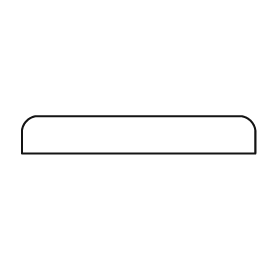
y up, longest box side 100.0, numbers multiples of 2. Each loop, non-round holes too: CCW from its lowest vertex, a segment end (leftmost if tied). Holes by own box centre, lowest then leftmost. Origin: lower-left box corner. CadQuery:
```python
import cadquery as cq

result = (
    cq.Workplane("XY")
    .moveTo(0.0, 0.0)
    .lineTo(100.0, 0.0)
    .lineTo(100.0, 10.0)
    .threePointArc((98.0, 14.0), (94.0, 16.0))
    .lineTo(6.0, 16.0)
    .threePointArc((2.0, 14.0), (0.0, 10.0))
    .close()
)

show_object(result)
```